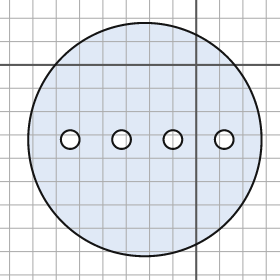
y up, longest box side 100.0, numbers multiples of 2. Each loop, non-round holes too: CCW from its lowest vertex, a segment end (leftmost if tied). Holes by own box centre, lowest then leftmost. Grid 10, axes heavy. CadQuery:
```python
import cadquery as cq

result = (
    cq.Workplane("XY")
    .moveTo(-22.0, -32.0)
    .circle(50.0)
    .moveTo(-54.0, -32.0)
    .circle(4.0)
    .moveTo(-32.0, -32.0)
    .circle(4.0)
    .moveTo(-10.0, -32.0)
    .circle(4.0)
    .moveTo(12.0, -32.0)
    .circle(4.0)
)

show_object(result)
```